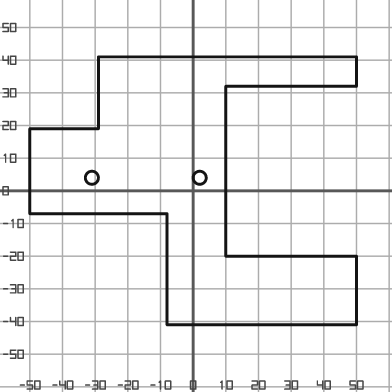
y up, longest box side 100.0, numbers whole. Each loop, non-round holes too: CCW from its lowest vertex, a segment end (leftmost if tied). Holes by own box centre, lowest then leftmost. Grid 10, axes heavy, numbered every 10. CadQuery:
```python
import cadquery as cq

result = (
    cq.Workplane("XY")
    .moveTo(-8.0, -41.0)
    .lineTo(50.0, -41.0)
    .lineTo(50.0, -20.0)
    .lineTo(10.0, -20.0)
    .lineTo(10.0, 32.0)
    .lineTo(50.0, 32.0)
    .lineTo(50.0, 41.0)
    .lineTo(-29.0, 41.0)
    .lineTo(-29.0, 19.0)
    .lineTo(-50.0, 19.0)
    .lineTo(-50.0, -7.0)
    .lineTo(-8.0, -7.0)
    .close()
    .moveTo(-31.0, 4.0)
    .circle(2.0)
    .moveTo(2.0, 4.0)
    .circle(2.0)
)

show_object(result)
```